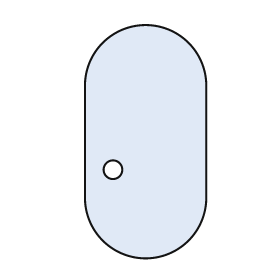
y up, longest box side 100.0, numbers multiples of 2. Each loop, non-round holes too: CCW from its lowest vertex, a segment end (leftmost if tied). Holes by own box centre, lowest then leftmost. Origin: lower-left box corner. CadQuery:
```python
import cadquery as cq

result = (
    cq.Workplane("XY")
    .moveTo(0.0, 26.0)
    .threePointArc((26.0, 0.0), (52.0, 26.0))
    .lineTo(52.0, 74.0)
    .threePointArc((26.0, 100.0), (0.0, 74.0))
    .close()
    .moveTo(12.0, 38.0)
    .circle(4.0)
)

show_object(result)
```